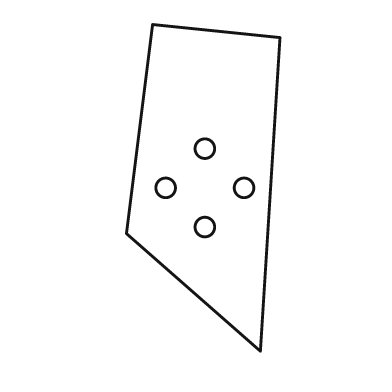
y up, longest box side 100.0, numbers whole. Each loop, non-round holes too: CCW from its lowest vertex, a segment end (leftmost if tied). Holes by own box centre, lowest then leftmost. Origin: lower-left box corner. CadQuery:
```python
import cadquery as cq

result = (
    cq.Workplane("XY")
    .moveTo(41.0, 0.0)
    .lineTo(47.0, 96.0)
    .lineTo(8.0, 100.0)
    .lineTo(0.0, 36.0)
    .close()
    .moveTo(24.0, 38.0)
    .circle(3.0)
    .moveTo(12.0, 50.0)
    .circle(3.0)
    .moveTo(36.0, 50.0)
    .circle(3.0)
    .moveTo(24.0, 62.0)
    .circle(3.0)
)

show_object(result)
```